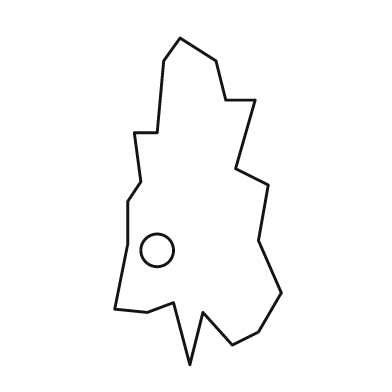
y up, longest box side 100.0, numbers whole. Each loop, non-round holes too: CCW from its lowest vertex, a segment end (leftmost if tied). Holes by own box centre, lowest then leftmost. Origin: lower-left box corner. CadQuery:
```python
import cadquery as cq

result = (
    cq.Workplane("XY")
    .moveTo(23.0, 0.0)
    .lineTo(27.0, 16.0)
    .lineTo(36.0, 6.0)
    .lineTo(44.0, 10.0)
    .lineTo(51.0, 22.0)
    .lineTo(44.0, 38.0)
    .lineTo(47.0, 55.0)
    .lineTo(37.0, 60.0)
    .lineTo(43.0, 81.0)
    .lineTo(34.0, 81.0)
    .lineTo(31.0, 93.0)
    .lineTo(20.0, 100.0)
    .lineTo(15.0, 93.0)
    .lineTo(13.0, 71.0)
    .lineTo(6.0, 71.0)
    .lineTo(8.0, 56.0)
    .lineTo(4.0, 50.0)
    .lineTo(4.0, 37.0)
    .lineTo(0.0, 17.0)
    .lineTo(10.0, 16.0)
    .lineTo(18.0, 19.0)
    .close()
    .moveTo(13.0, 35.0)
    .circle(5.0)
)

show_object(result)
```